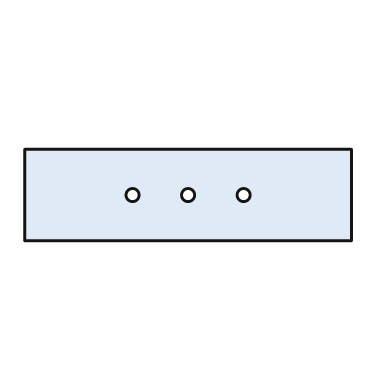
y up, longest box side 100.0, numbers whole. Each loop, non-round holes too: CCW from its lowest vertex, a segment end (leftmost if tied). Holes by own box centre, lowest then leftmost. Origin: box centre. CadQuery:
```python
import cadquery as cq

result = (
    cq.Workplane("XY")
    .moveTo(-50.0, -14.0)
    .lineTo(50.0, -14.0)
    .lineTo(50.0, 14.0)
    .lineTo(-50.0, 14.0)
    .close()
    .moveTo(-17.0, 0.0)
    .circle(2.0)
    .moveTo(0.0, 0.0)
    .circle(2.0)
    .moveTo(17.0, 0.0)
    .circle(2.0)
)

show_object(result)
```